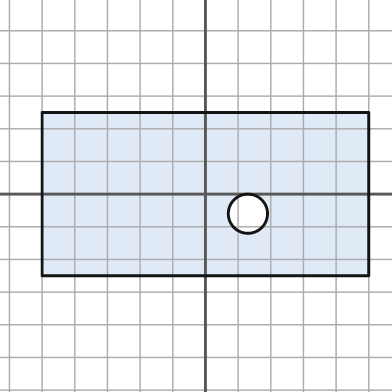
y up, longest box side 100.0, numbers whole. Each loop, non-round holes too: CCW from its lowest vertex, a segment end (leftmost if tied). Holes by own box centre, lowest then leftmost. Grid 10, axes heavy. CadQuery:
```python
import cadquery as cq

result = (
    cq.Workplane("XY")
    .moveTo(-50.0, -25.0)
    .lineTo(50.0, -25.0)
    .lineTo(50.0, 25.0)
    .lineTo(-50.0, 25.0)
    .close()
    .moveTo(13.0, -6.0)
    .circle(6.0)
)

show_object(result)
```